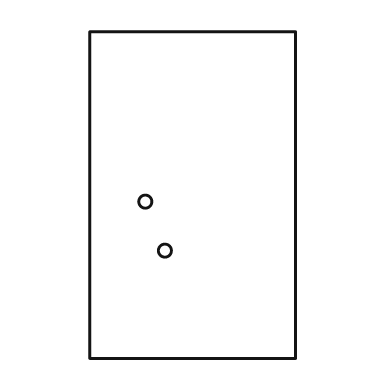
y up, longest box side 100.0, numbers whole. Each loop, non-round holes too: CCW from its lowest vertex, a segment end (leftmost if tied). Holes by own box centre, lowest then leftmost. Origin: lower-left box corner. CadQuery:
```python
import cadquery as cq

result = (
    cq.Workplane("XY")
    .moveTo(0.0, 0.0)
    .lineTo(63.0, 0.0)
    .lineTo(63.0, 100.0)
    .lineTo(0.0, 100.0)
    .close()
    .moveTo(23.0, 33.0)
    .circle(2.0)
    .moveTo(17.0, 48.0)
    .circle(2.0)
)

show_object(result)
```